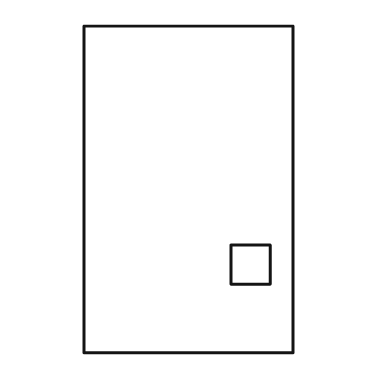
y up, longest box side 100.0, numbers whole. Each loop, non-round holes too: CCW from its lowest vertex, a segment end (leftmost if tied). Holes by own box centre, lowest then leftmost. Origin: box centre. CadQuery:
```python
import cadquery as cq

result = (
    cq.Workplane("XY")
    .moveTo(-32.0, -50.0)
    .lineTo(32.0, -50.0)
    .lineTo(32.0, 50.0)
    .lineTo(-32.0, 50.0)
    .close()
    .moveTo(13.0, -29.0)
    .lineTo(25.0, -29.0)
    .lineTo(25.0, -17.0)
    .lineTo(13.0, -17.0)
    .close()
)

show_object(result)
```